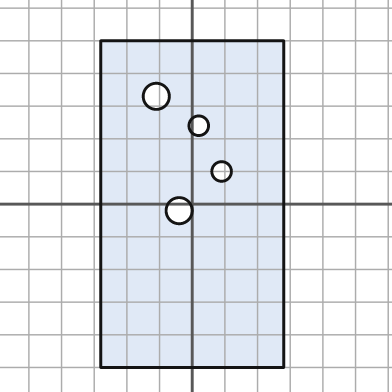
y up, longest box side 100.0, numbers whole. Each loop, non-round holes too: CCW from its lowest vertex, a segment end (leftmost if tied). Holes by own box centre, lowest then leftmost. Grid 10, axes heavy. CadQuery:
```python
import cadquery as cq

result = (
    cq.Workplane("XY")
    .moveTo(-28.0, -50.0)
    .lineTo(28.0, -50.0)
    .lineTo(28.0, 50.0)
    .lineTo(-28.0, 50.0)
    .close()
    .moveTo(-4.0, -2.0)
    .circle(4.0)
    .moveTo(9.0, 10.0)
    .circle(3.0)
    .moveTo(2.0, 24.0)
    .circle(3.0)
    .moveTo(-11.0, 33.0)
    .circle(4.0)
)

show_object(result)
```